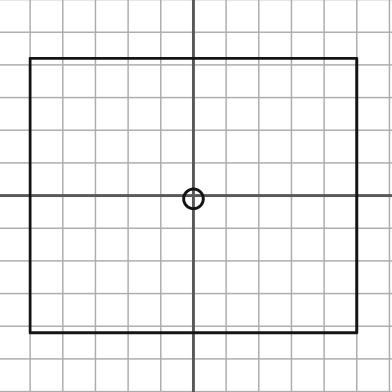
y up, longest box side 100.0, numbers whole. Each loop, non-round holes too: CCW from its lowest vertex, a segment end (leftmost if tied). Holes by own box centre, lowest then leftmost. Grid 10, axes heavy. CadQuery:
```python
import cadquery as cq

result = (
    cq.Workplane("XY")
    .moveTo(-50.0, -42.0)
    .lineTo(50.0, -42.0)
    .lineTo(50.0, 42.0)
    .lineTo(-50.0, 42.0)
    .close()
    .moveTo(0.0, -1.0)
    .circle(3.0)
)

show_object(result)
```